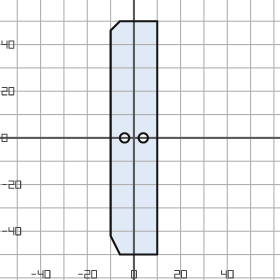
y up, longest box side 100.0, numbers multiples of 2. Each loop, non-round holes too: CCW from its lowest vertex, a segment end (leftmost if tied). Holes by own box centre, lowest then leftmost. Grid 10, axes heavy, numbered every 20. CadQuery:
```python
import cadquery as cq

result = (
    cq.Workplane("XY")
    .moveTo(-6.0, -50.0)
    .lineTo(10.0, -50.0)
    .lineTo(10.0, 50.0)
    .lineTo(-6.0, 50.0)
    .lineTo(-10.0, 46.0)
    .lineTo(-10.0, -42.0)
    .close()
    .moveTo(-4.0, 0.0)
    .circle(2.0)
    .moveTo(4.0, 0.0)
    .circle(2.0)
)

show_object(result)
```